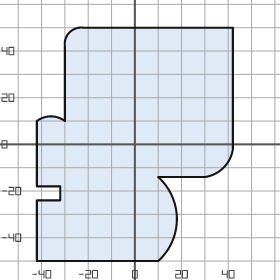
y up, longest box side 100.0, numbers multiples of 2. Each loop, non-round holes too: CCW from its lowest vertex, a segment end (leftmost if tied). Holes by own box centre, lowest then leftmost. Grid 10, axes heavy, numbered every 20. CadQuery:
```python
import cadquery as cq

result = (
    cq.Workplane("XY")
    .moveTo(-42.0, -50.0)
    .lineTo(10.0, -50.0)
    .threePointArc((18.0, -32.0), (10.0, -14.0))
    .lineTo(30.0, -14.0)
    .threePointArc((38.0, -10.0), (42.0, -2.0))
    .lineTo(42.0, 50.0)
    .lineTo(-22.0, 50.0)
    .threePointArc((-28.0, 48.0), (-30.0, 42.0))
    .lineTo(-30.0, 10.0)
    .threePointArc((-36.0, 12.0), (-42.0, 10.0))
    .lineTo(-42.0, -18.0)
    .lineTo(-32.0, -18.0)
    .lineTo(-32.0, -24.0)
    .lineTo(-42.0, -24.0)
    .close()
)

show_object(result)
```